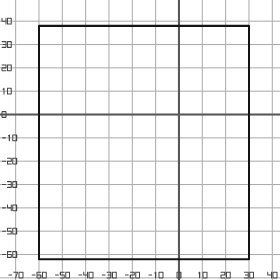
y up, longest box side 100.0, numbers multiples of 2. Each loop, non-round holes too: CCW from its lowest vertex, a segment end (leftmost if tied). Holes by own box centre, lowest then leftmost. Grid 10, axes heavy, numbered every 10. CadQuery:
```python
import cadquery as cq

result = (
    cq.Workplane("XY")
    .moveTo(-60.0, -62.0)
    .lineTo(30.0, -62.0)
    .lineTo(30.0, 38.0)
    .lineTo(-60.0, 38.0)
    .close()
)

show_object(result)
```